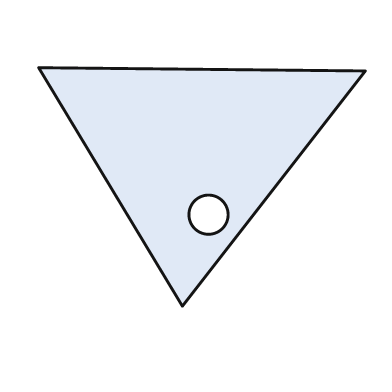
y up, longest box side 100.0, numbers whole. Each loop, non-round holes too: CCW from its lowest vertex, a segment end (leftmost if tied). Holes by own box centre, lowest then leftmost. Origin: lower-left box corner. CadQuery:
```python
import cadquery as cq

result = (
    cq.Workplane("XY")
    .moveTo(44.0, 0.0)
    .lineTo(100.0, 72.0)
    .lineTo(0.0, 73.0)
    .close()
    .moveTo(52.0, 28.0)
    .circle(6.0)
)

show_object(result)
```